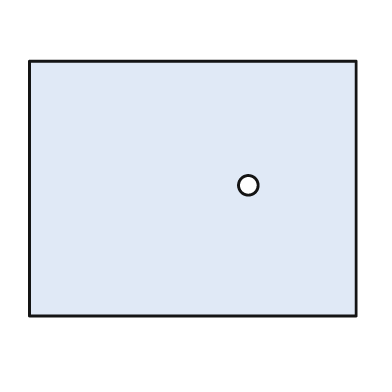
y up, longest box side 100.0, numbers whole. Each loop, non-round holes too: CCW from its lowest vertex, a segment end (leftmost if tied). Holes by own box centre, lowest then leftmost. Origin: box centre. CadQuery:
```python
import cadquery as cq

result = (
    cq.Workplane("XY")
    .moveTo(-50.0, -39.0)
    .lineTo(50.0, -39.0)
    .lineTo(50.0, 39.0)
    .lineTo(-50.0, 39.0)
    .close()
    .moveTo(17.0, 1.0)
    .circle(3.0)
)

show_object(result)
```